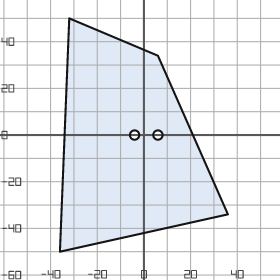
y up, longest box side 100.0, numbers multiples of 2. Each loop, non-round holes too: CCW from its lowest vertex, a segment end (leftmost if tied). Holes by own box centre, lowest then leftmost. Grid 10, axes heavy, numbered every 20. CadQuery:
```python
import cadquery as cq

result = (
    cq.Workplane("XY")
    .moveTo(-36.0, -50.0)
    .lineTo(36.0, -34.0)
    .lineTo(6.0, 34.0)
    .lineTo(-32.0, 50.0)
    .close()
    .moveTo(-4.0, 0.0)
    .circle(2.0)
    .moveTo(6.0, 0.0)
    .circle(2.0)
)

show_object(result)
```